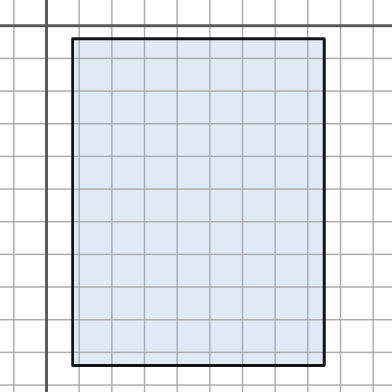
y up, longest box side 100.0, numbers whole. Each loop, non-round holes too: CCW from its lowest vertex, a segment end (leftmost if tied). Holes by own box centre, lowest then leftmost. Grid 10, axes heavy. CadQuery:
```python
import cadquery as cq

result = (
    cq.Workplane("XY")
    .moveTo(8.0, -104.0)
    .lineTo(85.0, -104.0)
    .lineTo(85.0, -4.0)
    .lineTo(8.0, -4.0)
    .close()
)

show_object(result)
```